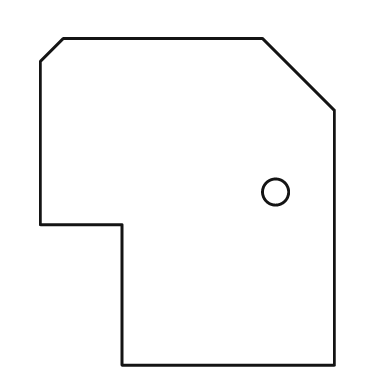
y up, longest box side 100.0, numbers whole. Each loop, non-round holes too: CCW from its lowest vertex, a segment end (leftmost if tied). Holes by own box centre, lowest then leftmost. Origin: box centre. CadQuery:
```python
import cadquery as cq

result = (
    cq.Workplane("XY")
    .moveTo(-20.0, -50.0)
    .lineTo(45.0, -50.0)
    .lineTo(45.0, 28.0)
    .lineTo(23.0, 50.0)
    .lineTo(-38.0, 50.0)
    .lineTo(-45.0, 43.0)
    .lineTo(-45.0, -7.0)
    .lineTo(-20.0, -7.0)
    .close()
    .moveTo(27.0, 3.0)
    .circle(4.0)
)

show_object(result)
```